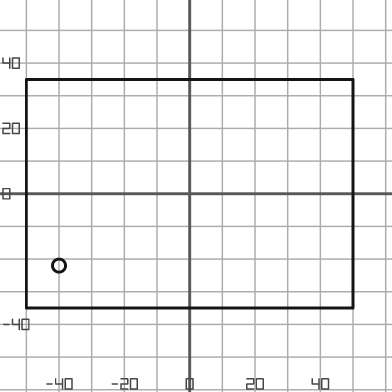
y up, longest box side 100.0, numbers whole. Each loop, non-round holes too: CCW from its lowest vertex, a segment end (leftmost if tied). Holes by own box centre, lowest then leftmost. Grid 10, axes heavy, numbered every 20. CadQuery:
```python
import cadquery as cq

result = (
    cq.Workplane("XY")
    .moveTo(-50.0, -35.0)
    .lineTo(50.0, -35.0)
    .lineTo(50.0, 35.0)
    .lineTo(-50.0, 35.0)
    .close()
    .moveTo(-40.0, -22.0)
    .circle(2.0)
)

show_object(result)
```